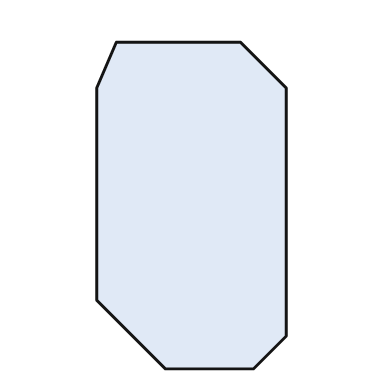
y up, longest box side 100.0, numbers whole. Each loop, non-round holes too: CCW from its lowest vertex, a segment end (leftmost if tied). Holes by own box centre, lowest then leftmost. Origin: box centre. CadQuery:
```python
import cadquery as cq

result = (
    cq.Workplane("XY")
    .moveTo(-8.0, -50.0)
    .lineTo(19.0, -50.0)
    .lineTo(29.0, -40.0)
    .lineTo(29.0, 36.0)
    .lineTo(15.0, 50.0)
    .lineTo(-23.0, 50.0)
    .lineTo(-29.0, 36.0)
    .lineTo(-29.0, -29.0)
    .close()
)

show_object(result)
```